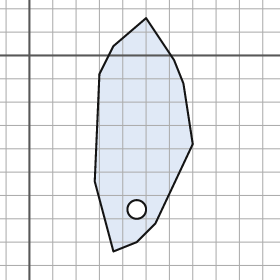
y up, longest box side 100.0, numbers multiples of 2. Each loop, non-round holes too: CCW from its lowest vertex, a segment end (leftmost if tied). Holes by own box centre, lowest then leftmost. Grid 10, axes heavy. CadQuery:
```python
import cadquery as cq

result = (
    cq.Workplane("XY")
    .moveTo(36.0, -84.0)
    .lineTo(46.0, -80.0)
    .lineTo(54.0, -72.0)
    .lineTo(70.0, -38.0)
    .lineTo(66.0, -12.0)
    .lineTo(62.0, -2.0)
    .lineTo(50.0, 16.0)
    .lineTo(36.0, 4.0)
    .lineTo(30.0, -8.0)
    .lineTo(28.0, -54.0)
    .close()
    .moveTo(46.0, -66.0)
    .circle(4.0)
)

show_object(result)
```